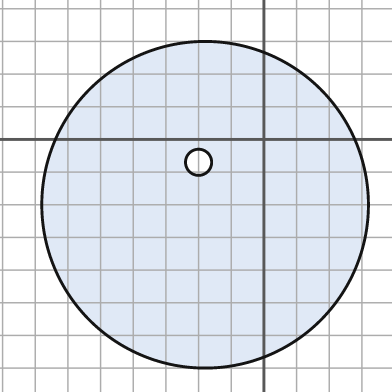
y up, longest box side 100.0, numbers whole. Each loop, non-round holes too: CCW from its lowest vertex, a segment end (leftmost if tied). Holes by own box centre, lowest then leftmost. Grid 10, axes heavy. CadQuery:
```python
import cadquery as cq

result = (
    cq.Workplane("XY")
    .moveTo(-18.0, -20.0)
    .circle(50.0)
    .moveTo(-20.0, -7.0)
    .circle(4.0)
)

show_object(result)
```